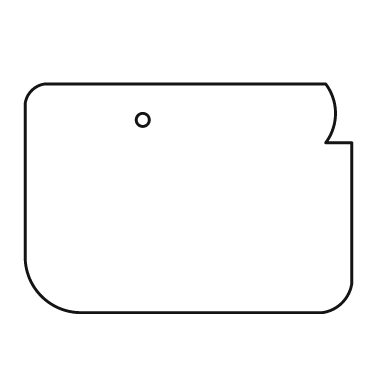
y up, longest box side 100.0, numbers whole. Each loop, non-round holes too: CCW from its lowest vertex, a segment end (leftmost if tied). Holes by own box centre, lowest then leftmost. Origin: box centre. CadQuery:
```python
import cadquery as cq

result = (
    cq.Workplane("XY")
    .moveTo(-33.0, -35.0)
    .lineTo(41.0, -35.0)
    .threePointArc((47.0, -32.0), (50.0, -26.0))
    .lineTo(50.0, 17.0)
    .lineTo(42.0, 17.0)
    .threePointArc((45.0, 26.0), (42.0, 35.0))
    .lineTo(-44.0, 35.0)
    .threePointArc((-48.0, 33.0), (-50.0, 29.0))
    .lineTo(-50.0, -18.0)
    .threePointArc((-45.0, -30.0), (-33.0, -35.0))
    .close()
    .moveTo(-14.0, 24.0)
    .circle(2.0)
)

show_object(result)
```